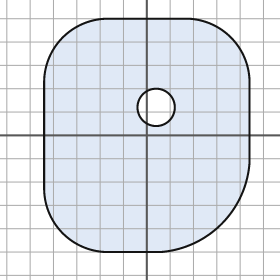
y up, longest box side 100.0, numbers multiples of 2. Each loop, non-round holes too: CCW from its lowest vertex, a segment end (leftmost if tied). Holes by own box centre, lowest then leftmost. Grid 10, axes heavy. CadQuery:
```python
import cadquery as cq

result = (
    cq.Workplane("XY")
    .moveTo(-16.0, -50.0)
    .lineTo(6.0, -50.0)
    .threePointArc((32.0, -38.0), (44.0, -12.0))
    .lineTo(44.0, 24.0)
    .threePointArc((36.0, 42.0), (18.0, 50.0))
    .lineTo(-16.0, 50.0)
    .threePointArc((-36.0, 42.0), (-44.0, 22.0))
    .lineTo(-44.0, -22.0)
    .threePointArc((-36.0, -42.0), (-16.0, -50.0))
    .close()
    .moveTo(4.0, 12.0)
    .circle(8.0)
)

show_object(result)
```